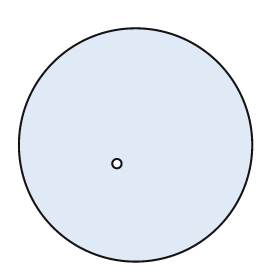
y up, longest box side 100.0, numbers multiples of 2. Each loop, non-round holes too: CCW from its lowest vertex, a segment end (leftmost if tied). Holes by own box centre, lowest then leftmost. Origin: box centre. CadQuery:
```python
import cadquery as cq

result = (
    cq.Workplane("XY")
    .moveTo(0.0, 0.0)
    .circle(50.0)
    .moveTo(-8.0, -8.0)
    .circle(2.0)
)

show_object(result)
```